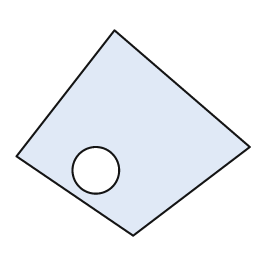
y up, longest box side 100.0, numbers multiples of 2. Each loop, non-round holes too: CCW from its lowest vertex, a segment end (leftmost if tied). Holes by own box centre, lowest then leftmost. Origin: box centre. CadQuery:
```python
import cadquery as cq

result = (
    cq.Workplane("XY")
    .moveTo(0.0, -44.0)
    .lineTo(50.0, -6.0)
    .lineTo(-8.0, 44.0)
    .lineTo(-50.0, -10.0)
    .close()
    .moveTo(-16.0, -16.0)
    .circle(10.0)
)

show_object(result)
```